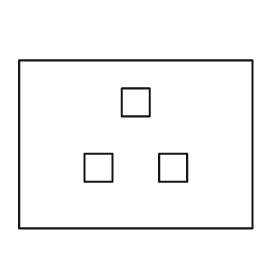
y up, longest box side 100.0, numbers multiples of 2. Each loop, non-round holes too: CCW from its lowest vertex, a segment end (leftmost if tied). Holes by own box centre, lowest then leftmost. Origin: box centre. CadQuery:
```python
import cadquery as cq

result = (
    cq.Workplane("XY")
    .moveTo(-50.0, -36.0)
    .lineTo(50.0, -36.0)
    .lineTo(50.0, 36.0)
    .lineTo(-50.0, 36.0)
    .close()
    .moveTo(-22.0, -16.0)
    .lineTo(-10.0, -16.0)
    .lineTo(-10.0, -4.0)
    .lineTo(-22.0, -4.0)
    .close()
    .moveTo(10.0, -16.0)
    .lineTo(22.0, -16.0)
    .lineTo(22.0, -4.0)
    .lineTo(10.0, -4.0)
    .close()
    .moveTo(-6.0, 12.0)
    .lineTo(6.0, 12.0)
    .lineTo(6.0, 24.0)
    .lineTo(-6.0, 24.0)
    .close()
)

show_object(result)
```